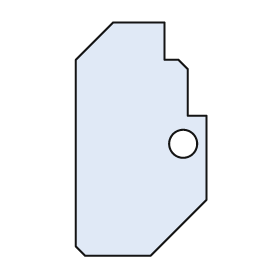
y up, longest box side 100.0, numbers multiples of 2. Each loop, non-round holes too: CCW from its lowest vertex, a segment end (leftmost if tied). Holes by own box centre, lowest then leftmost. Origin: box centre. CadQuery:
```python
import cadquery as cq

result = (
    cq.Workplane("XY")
    .moveTo(-24.0, -50.0)
    .lineTo(4.0, -50.0)
    .lineTo(28.0, -26.0)
    .lineTo(28.0, 10.0)
    .lineTo(20.0, 10.0)
    .lineTo(20.0, 30.0)
    .lineTo(16.0, 34.0)
    .lineTo(10.0, 34.0)
    .lineTo(10.0, 50.0)
    .lineTo(-12.0, 50.0)
    .lineTo(-28.0, 34.0)
    .lineTo(-28.0, -46.0)
    .close()
    .moveTo(18.0, -2.0)
    .circle(6.0)
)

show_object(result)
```